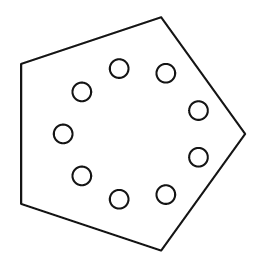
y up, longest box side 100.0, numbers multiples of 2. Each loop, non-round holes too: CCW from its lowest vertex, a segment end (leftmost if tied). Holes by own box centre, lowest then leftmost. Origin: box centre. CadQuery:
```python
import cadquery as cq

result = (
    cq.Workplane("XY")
    .moveTo(12.0, -50.0)
    .lineTo(48.0, 0.0)
    .lineTo(12.0, 50.0)
    .lineTo(-48.0, 30.0)
    .lineTo(-48.0, -30.0)
    .close()
    .moveTo(-6.0, -28.0)
    .circle(4.0)
    .moveTo(14.0, -26.0)
    .circle(4.0)
    .moveTo(-22.0, -18.0)
    .circle(4.0)
    .moveTo(28.0, -10.0)
    .circle(4.0)
    .moveTo(-30.0, 0.0)
    .circle(4.0)
    .moveTo(28.0, 10.0)
    .circle(4.0)
    .moveTo(-22.0, 18.0)
    .circle(4.0)
    .moveTo(14.0, 26.0)
    .circle(4.0)
    .moveTo(-6.0, 28.0)
    .circle(4.0)
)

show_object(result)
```